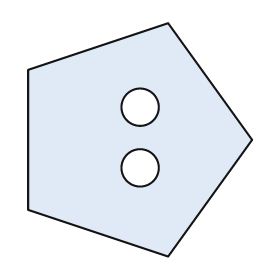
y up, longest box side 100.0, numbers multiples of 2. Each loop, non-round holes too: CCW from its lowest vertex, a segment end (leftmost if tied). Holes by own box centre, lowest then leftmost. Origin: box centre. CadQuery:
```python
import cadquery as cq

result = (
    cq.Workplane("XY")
    .moveTo(12.0, -50.0)
    .lineTo(48.0, 0.0)
    .lineTo(12.0, 50.0)
    .lineTo(-48.0, 30.0)
    .lineTo(-48.0, -30.0)
    .close()
    .moveTo(0.0, -12.0)
    .circle(8.0)
    .moveTo(0.0, 14.0)
    .circle(8.0)
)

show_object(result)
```